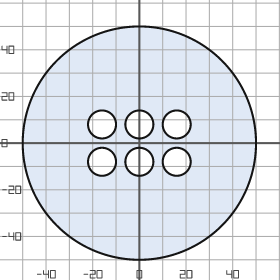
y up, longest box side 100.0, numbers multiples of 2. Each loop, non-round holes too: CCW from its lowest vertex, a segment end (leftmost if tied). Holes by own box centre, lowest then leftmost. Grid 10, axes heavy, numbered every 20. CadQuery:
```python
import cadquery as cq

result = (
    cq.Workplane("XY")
    .moveTo(0.0, 0.0)
    .circle(50.0)
    .moveTo(-16.0, -8.0)
    .circle(6.0)
    .moveTo(0.0, -8.0)
    .circle(6.0)
    .moveTo(16.0, -8.0)
    .circle(6.0)
    .moveTo(-16.0, 8.0)
    .circle(6.0)
    .moveTo(0.0, 8.0)
    .circle(6.0)
    .moveTo(16.0, 8.0)
    .circle(6.0)
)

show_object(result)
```